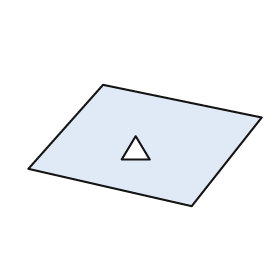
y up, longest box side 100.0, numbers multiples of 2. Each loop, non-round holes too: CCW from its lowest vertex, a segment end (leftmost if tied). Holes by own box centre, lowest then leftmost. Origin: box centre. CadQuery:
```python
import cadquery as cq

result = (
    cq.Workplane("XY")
    .moveTo(20.0, -26.0)
    .lineTo(50.0, 12.0)
    .lineTo(-18.0, 26.0)
    .lineTo(-50.0, -10.0)
    .close()
    .moveTo(-10.0, -6.0)
    .lineTo(2.0, -6.0)
    .lineTo(-4.0, 4.0)
    .close()
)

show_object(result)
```